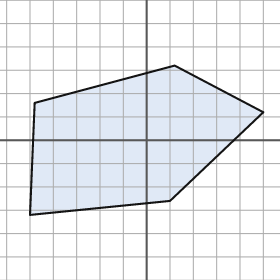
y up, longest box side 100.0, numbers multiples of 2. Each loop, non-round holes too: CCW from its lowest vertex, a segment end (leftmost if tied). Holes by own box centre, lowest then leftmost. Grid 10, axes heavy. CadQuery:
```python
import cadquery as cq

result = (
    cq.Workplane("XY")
    .moveTo(-50.0, -32.0)
    .lineTo(10.0, -26.0)
    .lineTo(50.0, 12.0)
    .lineTo(12.0, 32.0)
    .lineTo(-48.0, 16.0)
    .close()
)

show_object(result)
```